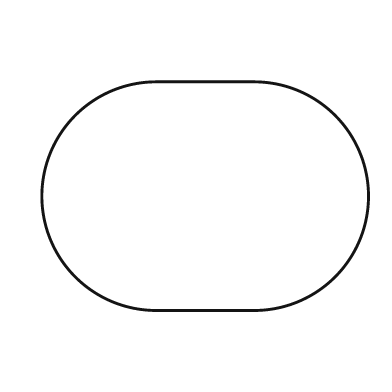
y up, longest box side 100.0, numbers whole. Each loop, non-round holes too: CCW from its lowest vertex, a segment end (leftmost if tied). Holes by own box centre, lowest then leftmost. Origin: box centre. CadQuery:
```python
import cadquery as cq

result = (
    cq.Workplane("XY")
    .moveTo(-15.0, -35.0)
    .lineTo(15.0, -35.0)
    .threePointArc((50.0, 0.0), (15.0, 35.0))
    .lineTo(-15.0, 35.0)
    .threePointArc((-50.0, 0.0), (-15.0, -35.0))
    .close()
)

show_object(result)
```